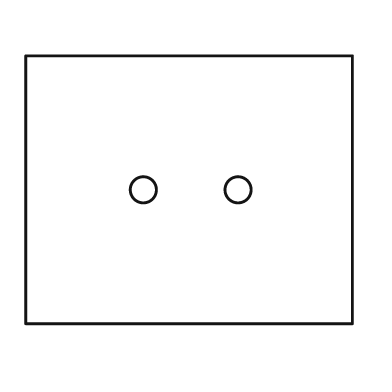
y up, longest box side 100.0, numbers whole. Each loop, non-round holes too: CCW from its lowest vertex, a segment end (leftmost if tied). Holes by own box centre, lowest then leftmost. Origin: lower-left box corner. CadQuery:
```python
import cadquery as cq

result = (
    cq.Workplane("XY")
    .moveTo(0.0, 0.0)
    .lineTo(100.0, 0.0)
    .lineTo(100.0, 82.0)
    .lineTo(0.0, 82.0)
    .close()
    .moveTo(36.0, 41.0)
    .circle(4.0)
    .moveTo(65.0, 41.0)
    .circle(4.0)
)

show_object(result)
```